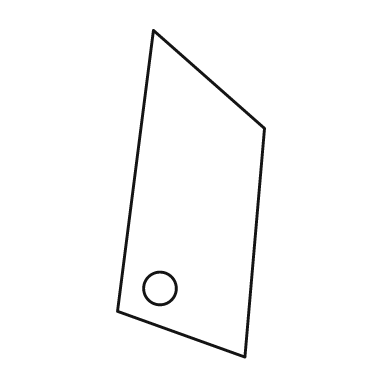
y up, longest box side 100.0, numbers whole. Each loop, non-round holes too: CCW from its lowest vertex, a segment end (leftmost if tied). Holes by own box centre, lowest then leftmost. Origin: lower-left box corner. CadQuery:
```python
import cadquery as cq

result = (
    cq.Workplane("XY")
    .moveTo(39.0, 0.0)
    .lineTo(45.0, 70.0)
    .lineTo(11.0, 100.0)
    .lineTo(0.0, 14.0)
    .close()
    .moveTo(13.0, 21.0)
    .circle(5.0)
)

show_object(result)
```